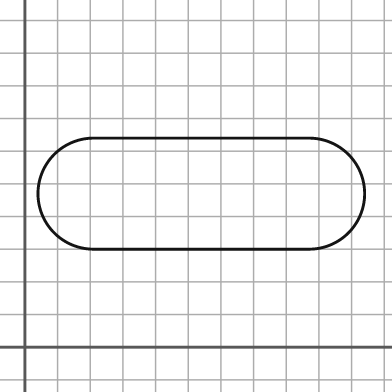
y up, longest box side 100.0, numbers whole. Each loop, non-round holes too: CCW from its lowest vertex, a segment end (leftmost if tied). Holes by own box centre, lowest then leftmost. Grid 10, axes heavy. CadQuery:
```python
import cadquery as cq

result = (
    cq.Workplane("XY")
    .moveTo(21.0, 30.0)
    .lineTo(87.0, 30.0)
    .threePointArc((104.0, 47.0), (87.0, 64.0))
    .lineTo(21.0, 64.0)
    .threePointArc((4.0, 47.0), (21.0, 30.0))
    .close()
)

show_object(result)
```